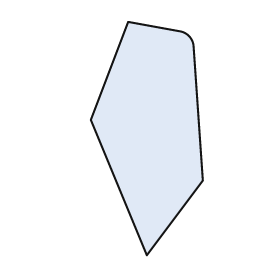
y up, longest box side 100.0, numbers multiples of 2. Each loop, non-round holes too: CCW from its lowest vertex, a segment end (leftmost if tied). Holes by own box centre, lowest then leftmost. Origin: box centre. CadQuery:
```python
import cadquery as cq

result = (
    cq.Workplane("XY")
    .moveTo(0.0, -50.0)
    .lineTo(24.0, -18.0)
    .lineTo(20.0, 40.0)
    .threePointArc((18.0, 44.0), (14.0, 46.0))
    .lineTo(-8.0, 50.0)
    .lineTo(-24.0, 8.0)
    .close()
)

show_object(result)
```